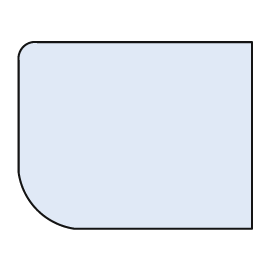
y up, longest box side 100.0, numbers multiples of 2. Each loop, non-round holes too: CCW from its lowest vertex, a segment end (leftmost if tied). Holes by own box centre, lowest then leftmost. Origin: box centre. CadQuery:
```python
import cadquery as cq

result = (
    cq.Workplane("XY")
    .moveTo(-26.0, -40.0)
    .lineTo(50.0, -40.0)
    .lineTo(50.0, 40.0)
    .lineTo(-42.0, 40.0)
    .threePointArc((-48.0, 38.0), (-50.0, 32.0))
    .lineTo(-50.0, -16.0)
    .threePointArc((-42.0, -32.0), (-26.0, -40.0))
    .close()
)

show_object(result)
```